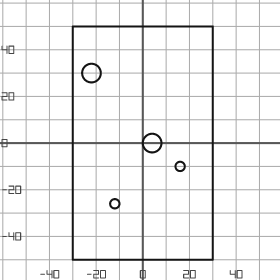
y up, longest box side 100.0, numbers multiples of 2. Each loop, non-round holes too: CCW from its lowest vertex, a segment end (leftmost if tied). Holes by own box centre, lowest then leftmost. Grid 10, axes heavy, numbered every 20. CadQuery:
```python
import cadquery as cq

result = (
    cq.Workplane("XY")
    .moveTo(-30.0, -50.0)
    .lineTo(30.0, -50.0)
    .lineTo(30.0, 50.0)
    .lineTo(-30.0, 50.0)
    .close()
    .moveTo(-12.0, -26.0)
    .circle(2.0)
    .moveTo(16.0, -10.0)
    .circle(2.0)
    .moveTo(4.0, 0.0)
    .circle(4.0)
    .moveTo(-22.0, 30.0)
    .circle(4.0)
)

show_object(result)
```